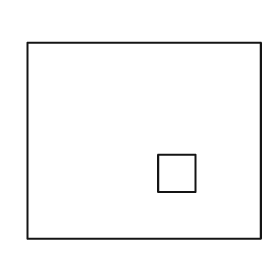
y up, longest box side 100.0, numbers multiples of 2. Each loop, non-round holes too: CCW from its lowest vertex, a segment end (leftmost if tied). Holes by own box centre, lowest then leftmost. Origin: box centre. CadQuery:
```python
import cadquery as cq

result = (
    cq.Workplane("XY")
    .moveTo(-50.0, -42.0)
    .lineTo(50.0, -42.0)
    .lineTo(50.0, 42.0)
    .lineTo(-50.0, 42.0)
    .close()
    .moveTo(6.0, -22.0)
    .lineTo(22.0, -22.0)
    .lineTo(22.0, -6.0)
    .lineTo(6.0, -6.0)
    .close()
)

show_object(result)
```